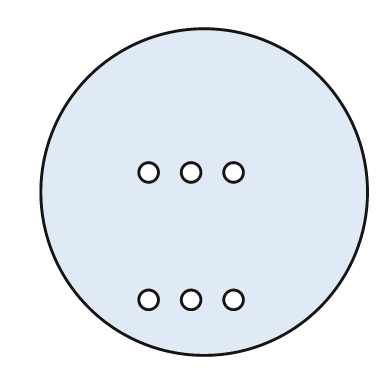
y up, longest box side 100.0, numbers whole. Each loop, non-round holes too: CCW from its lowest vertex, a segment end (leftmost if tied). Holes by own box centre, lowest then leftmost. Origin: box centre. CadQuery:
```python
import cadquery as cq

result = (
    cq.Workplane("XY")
    .moveTo(0.0, 0.0)
    .circle(50.0)
    .moveTo(-17.0, -33.0)
    .circle(3.0)
    .moveTo(-4.0, -33.0)
    .circle(3.0)
    .moveTo(9.0, -33.0)
    .circle(3.0)
    .moveTo(-17.0, 6.0)
    .circle(3.0)
    .moveTo(-4.0, 6.0)
    .circle(3.0)
    .moveTo(9.0, 6.0)
    .circle(3.0)
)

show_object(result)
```